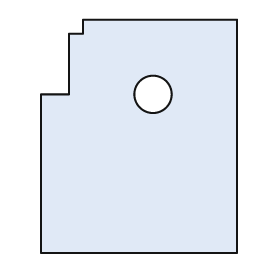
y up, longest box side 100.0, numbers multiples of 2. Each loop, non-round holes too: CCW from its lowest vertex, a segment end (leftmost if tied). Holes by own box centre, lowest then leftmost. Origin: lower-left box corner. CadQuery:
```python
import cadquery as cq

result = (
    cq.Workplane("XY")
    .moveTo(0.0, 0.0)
    .lineTo(84.0, 0.0)
    .lineTo(84.0, 100.0)
    .lineTo(18.0, 100.0)
    .lineTo(18.0, 94.0)
    .lineTo(12.0, 94.0)
    .lineTo(12.0, 68.0)
    .lineTo(0.0, 68.0)
    .close()
    .moveTo(48.0, 68.0)
    .circle(8.0)
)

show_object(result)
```